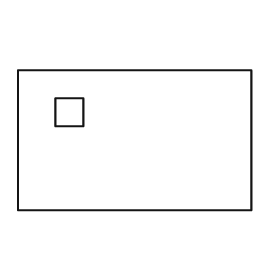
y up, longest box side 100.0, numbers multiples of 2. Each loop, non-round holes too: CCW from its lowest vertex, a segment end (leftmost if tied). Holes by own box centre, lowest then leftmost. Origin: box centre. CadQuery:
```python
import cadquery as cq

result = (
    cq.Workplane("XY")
    .moveTo(-50.0, -30.0)
    .lineTo(50.0, -30.0)
    .lineTo(50.0, 30.0)
    .lineTo(-50.0, 30.0)
    .close()
    .moveTo(-34.0, 6.0)
    .lineTo(-22.0, 6.0)
    .lineTo(-22.0, 18.0)
    .lineTo(-34.0, 18.0)
    .close()
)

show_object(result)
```